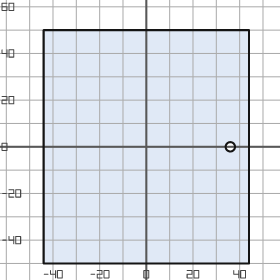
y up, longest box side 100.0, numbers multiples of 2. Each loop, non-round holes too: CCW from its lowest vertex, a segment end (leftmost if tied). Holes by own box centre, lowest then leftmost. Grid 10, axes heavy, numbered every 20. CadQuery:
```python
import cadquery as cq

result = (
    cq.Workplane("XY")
    .moveTo(-44.0, -50.0)
    .lineTo(44.0, -50.0)
    .lineTo(44.0, 50.0)
    .lineTo(-44.0, 50.0)
    .close()
    .moveTo(36.0, 0.0)
    .circle(2.0)
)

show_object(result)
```